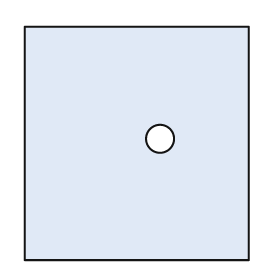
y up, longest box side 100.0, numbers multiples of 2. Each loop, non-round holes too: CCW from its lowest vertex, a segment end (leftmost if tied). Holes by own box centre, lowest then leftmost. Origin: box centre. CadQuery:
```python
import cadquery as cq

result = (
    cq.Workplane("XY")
    .moveTo(-48.0, -50.0)
    .lineTo(48.0, -50.0)
    .lineTo(48.0, 50.0)
    .lineTo(-48.0, 50.0)
    .close()
    .moveTo(10.0, 2.0)
    .circle(6.0)
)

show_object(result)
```